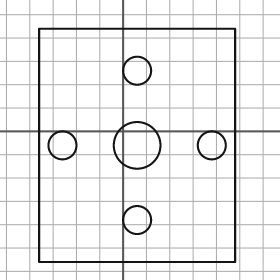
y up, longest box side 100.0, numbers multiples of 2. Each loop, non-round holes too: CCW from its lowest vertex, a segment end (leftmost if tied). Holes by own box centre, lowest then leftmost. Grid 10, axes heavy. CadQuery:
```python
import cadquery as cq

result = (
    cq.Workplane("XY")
    .moveTo(-36.0, -56.0)
    .lineTo(48.0, -56.0)
    .lineTo(48.0, 44.0)
    .lineTo(-36.0, 44.0)
    .close()
    .moveTo(6.0, -38.0)
    .circle(6.0)
    .moveTo(-26.0, -6.0)
    .circle(6.0)
    .moveTo(6.0, -6.0)
    .circle(10.0)
    .moveTo(38.0, -6.0)
    .circle(6.0)
    .moveTo(6.0, 26.0)
    .circle(6.0)
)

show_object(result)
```